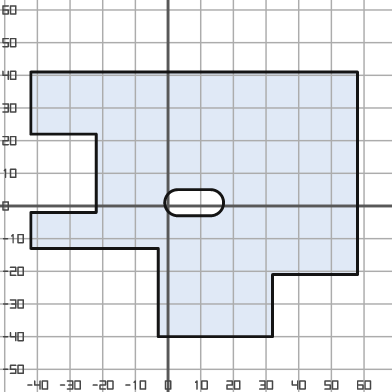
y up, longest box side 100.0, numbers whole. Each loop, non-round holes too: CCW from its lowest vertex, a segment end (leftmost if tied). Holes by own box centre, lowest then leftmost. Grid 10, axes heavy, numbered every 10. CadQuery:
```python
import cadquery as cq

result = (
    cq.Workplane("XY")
    .moveTo(-3.0, -40.0)
    .lineTo(32.0, -40.0)
    .lineTo(32.0, -21.0)
    .lineTo(58.0, -21.0)
    .lineTo(58.0, 41.0)
    .lineTo(-42.0, 41.0)
    .lineTo(-42.0, 22.0)
    .lineTo(-22.0, 22.0)
    .lineTo(-22.0, -2.0)
    .lineTo(-42.0, -2.0)
    .lineTo(-42.0, -13.0)
    .lineTo(-3.0, -13.0)
    .close()
    .moveTo(3.0, -3.0)
    .lineTo(13.0, -3.0)
    .threePointArc((17.0, 1.0), (13.0, 5.0))
    .lineTo(3.0, 5.0)
    .threePointArc((-1.0, 1.0), (3.0, -3.0))
    .close()
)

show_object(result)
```